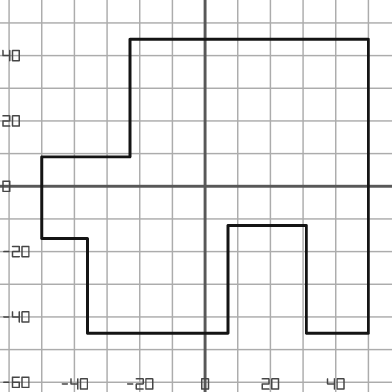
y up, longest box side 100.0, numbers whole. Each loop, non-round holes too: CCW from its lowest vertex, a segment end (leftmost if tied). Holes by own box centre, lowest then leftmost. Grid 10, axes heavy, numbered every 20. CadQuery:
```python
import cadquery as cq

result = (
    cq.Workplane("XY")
    .moveTo(-36.0, -45.0)
    .lineTo(7.0, -45.0)
    .lineTo(7.0, -12.0)
    .lineTo(31.0, -12.0)
    .lineTo(31.0, -45.0)
    .lineTo(50.0, -45.0)
    .lineTo(50.0, 45.0)
    .lineTo(-23.0, 45.0)
    .lineTo(-23.0, 9.0)
    .lineTo(-50.0, 9.0)
    .lineTo(-50.0, -16.0)
    .lineTo(-36.0, -16.0)
    .close()
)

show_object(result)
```